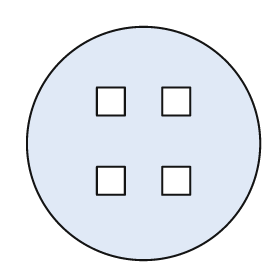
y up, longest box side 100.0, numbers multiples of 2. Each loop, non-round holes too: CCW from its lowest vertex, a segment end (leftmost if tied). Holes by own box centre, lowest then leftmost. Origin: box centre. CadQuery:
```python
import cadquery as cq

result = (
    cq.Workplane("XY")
    .moveTo(0.0, 0.0)
    .circle(50.0)
    .moveTo(-20.0, -22.0)
    .lineTo(-8.0, -22.0)
    .lineTo(-8.0, -10.0)
    .lineTo(-20.0, -10.0)
    .close()
    .moveTo(8.0, -22.0)
    .lineTo(20.0, -22.0)
    .lineTo(20.0, -10.0)
    .lineTo(8.0, -10.0)
    .close()
    .moveTo(-20.0, 12.0)
    .lineTo(-8.0, 12.0)
    .lineTo(-8.0, 24.0)
    .lineTo(-20.0, 24.0)
    .close()
    .moveTo(8.0, 12.0)
    .lineTo(20.0, 12.0)
    .lineTo(20.0, 24.0)
    .lineTo(8.0, 24.0)
    .close()
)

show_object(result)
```